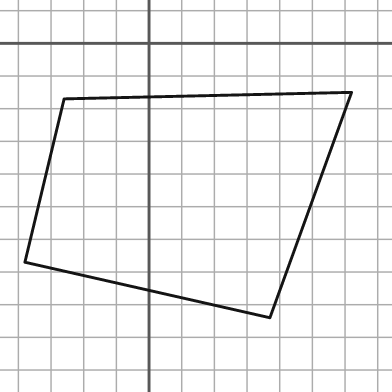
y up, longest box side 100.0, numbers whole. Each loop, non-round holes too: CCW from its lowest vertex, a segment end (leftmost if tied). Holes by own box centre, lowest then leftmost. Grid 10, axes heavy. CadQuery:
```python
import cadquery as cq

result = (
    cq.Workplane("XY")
    .moveTo(37.0, -84.0)
    .lineTo(62.0, -15.0)
    .lineTo(-26.0, -17.0)
    .lineTo(-38.0, -67.0)
    .close()
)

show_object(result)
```